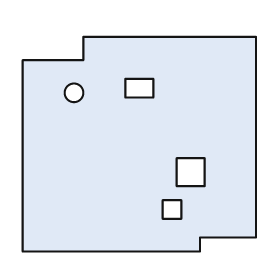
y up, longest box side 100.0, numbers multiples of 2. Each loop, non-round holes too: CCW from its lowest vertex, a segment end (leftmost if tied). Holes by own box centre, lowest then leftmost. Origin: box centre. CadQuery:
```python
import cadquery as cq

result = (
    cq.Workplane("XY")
    .moveTo(-50.0, -46.0)
    .lineTo(26.0, -46.0)
    .lineTo(26.0, -40.0)
    .lineTo(50.0, -40.0)
    .lineTo(50.0, 46.0)
    .lineTo(-24.0, 46.0)
    .lineTo(-24.0, 36.0)
    .lineTo(-50.0, 36.0)
    .close()
    .moveTo(10.0, -32.0)
    .lineTo(18.0, -32.0)
    .lineTo(18.0, -24.0)
    .lineTo(10.0, -24.0)
    .close()
    .moveTo(16.0, -18.0)
    .lineTo(28.0, -18.0)
    .lineTo(28.0, -6.0)
    .lineTo(16.0, -6.0)
    .close()
    .moveTo(-28.0, 22.0)
    .circle(4.0)
    .moveTo(-6.0, 20.0)
    .lineTo(6.0, 20.0)
    .lineTo(6.0, 28.0)
    .lineTo(-6.0, 28.0)
    .close()
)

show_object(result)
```